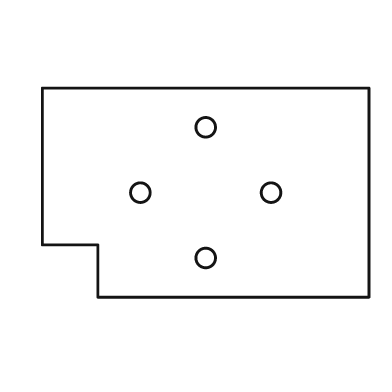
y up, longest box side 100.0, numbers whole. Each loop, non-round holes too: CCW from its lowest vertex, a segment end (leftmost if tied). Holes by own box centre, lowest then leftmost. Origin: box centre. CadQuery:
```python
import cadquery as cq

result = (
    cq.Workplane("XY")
    .moveTo(-33.0, -32.0)
    .lineTo(50.0, -32.0)
    .lineTo(50.0, 32.0)
    .lineTo(-50.0, 32.0)
    .lineTo(-50.0, -16.0)
    .lineTo(-33.0, -16.0)
    .close()
    .moveTo(0.0, -20.0)
    .circle(3.0)
    .moveTo(-20.0, 0.0)
    .circle(3.0)
    .moveTo(20.0, 0.0)
    .circle(3.0)
    .moveTo(0.0, 20.0)
    .circle(3.0)
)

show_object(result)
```